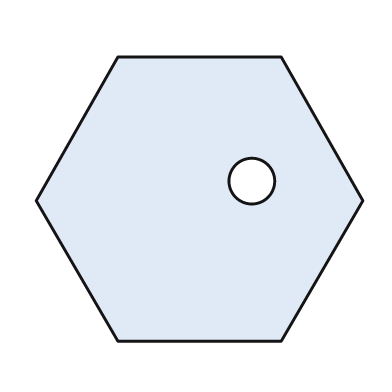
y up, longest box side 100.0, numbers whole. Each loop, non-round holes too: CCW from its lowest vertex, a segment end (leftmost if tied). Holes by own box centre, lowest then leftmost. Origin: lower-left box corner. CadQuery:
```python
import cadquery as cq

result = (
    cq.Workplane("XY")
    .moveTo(25.0, 0.0)
    .lineTo(75.0, 0.0)
    .lineTo(100.0, 43.0)
    .lineTo(75.0, 87.0)
    .lineTo(25.0, 87.0)
    .lineTo(0.0, 43.0)
    .close()
    .moveTo(66.0, 49.0)
    .circle(7.0)
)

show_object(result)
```